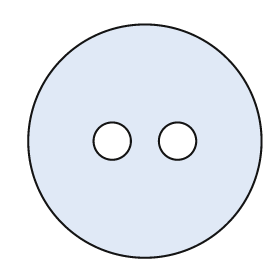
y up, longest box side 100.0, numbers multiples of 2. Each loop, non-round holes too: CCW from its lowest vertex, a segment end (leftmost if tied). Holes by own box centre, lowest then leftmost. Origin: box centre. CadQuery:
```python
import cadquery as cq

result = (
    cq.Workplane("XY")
    .moveTo(0.0, 0.0)
    .circle(50.0)
    .moveTo(-14.0, 0.0)
    .circle(8.0)
    .moveTo(14.0, 0.0)
    .circle(8.0)
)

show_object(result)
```